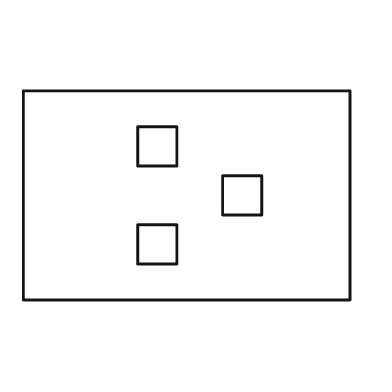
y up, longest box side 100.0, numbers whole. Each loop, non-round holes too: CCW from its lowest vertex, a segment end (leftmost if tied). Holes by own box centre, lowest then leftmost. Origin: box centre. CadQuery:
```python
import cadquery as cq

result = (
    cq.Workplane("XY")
    .moveTo(-50.0, -32.0)
    .lineTo(50.0, -32.0)
    .lineTo(50.0, 32.0)
    .lineTo(-50.0, 32.0)
    .close()
    .moveTo(-15.0, -21.0)
    .lineTo(-3.0, -21.0)
    .lineTo(-3.0, -9.0)
    .lineTo(-15.0, -9.0)
    .close()
    .moveTo(11.0, -6.0)
    .lineTo(23.0, -6.0)
    .lineTo(23.0, 6.0)
    .lineTo(11.0, 6.0)
    .close()
    .moveTo(-15.0, 9.0)
    .lineTo(-3.0, 9.0)
    .lineTo(-3.0, 21.0)
    .lineTo(-15.0, 21.0)
    .close()
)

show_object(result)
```